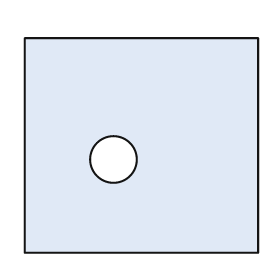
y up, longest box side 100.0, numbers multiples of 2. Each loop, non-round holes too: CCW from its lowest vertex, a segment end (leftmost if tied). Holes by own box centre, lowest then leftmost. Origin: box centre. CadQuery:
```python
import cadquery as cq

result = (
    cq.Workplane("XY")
    .moveTo(-50.0, -46.0)
    .lineTo(50.0, -46.0)
    .lineTo(50.0, 46.0)
    .lineTo(-50.0, 46.0)
    .close()
    .moveTo(-12.0, -6.0)
    .circle(10.0)
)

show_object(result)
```